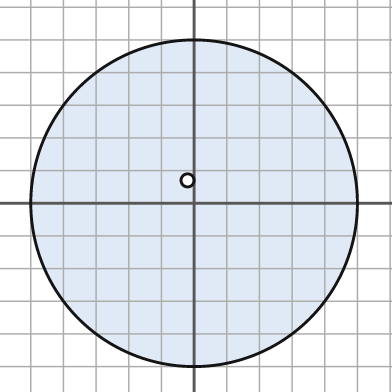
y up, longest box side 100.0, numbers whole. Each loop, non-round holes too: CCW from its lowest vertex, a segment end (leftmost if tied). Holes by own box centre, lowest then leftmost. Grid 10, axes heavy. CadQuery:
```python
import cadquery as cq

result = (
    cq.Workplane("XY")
    .moveTo(0.0, 0.0)
    .circle(50.0)
    .moveTo(-2.0, 7.0)
    .circle(2.0)
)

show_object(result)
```